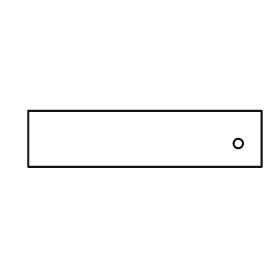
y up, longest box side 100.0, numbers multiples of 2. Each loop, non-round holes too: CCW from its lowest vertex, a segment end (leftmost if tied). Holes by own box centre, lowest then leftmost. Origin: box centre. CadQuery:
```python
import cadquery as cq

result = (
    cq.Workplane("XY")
    .moveTo(-50.0, -12.0)
    .lineTo(50.0, -12.0)
    .lineTo(50.0, 12.0)
    .lineTo(-50.0, 12.0)
    .close()
    .moveTo(40.0, -2.0)
    .circle(2.0)
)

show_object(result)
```